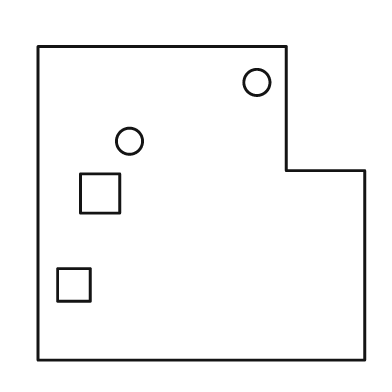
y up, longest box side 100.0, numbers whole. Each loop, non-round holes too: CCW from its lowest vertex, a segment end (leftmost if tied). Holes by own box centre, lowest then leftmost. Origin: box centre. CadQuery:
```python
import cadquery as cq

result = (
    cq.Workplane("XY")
    .moveTo(-50.0, -48.0)
    .lineTo(50.0, -48.0)
    .lineTo(50.0, 10.0)
    .lineTo(26.0, 10.0)
    .lineTo(26.0, 48.0)
    .lineTo(-50.0, 48.0)
    .close()
    .moveTo(-44.0, -30.0)
    .lineTo(-34.0, -30.0)
    .lineTo(-34.0, -20.0)
    .lineTo(-44.0, -20.0)
    .close()
    .moveTo(-37.0, -3.0)
    .lineTo(-25.0, -3.0)
    .lineTo(-25.0, 9.0)
    .lineTo(-37.0, 9.0)
    .close()
    .moveTo(-22.0, 19.0)
    .circle(4.0)
    .moveTo(17.0, 37.0)
    .circle(4.0)
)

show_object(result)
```